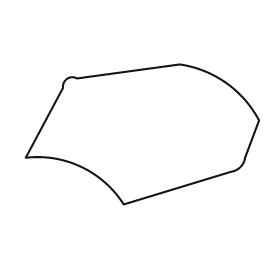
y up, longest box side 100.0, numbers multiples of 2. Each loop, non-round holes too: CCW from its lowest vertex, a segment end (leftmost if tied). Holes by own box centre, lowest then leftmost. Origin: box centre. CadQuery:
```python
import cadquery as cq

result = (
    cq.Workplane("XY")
    .moveTo(-8.0, -30.0)
    .lineTo(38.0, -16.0)
    .threePointArc((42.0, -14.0), (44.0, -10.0))
    .lineTo(50.0, 6.0)
    .threePointArc((36.0, 22.0), (16.0, 30.0))
    .lineTo(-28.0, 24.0)
    .threePointArc((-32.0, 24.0), (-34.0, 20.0))
    .lineTo(-50.0, -10.0)
    .threePointArc((-26.0, -14.0), (-8.0, -30.0))
    .close()
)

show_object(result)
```